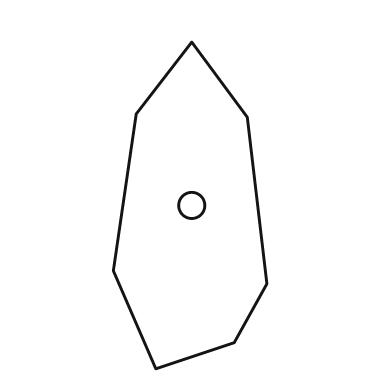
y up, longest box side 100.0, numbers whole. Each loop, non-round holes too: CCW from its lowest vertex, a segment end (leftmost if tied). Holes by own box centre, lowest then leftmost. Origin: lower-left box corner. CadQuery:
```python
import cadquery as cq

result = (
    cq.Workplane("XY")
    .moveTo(13.0, 0.0)
    .lineTo(37.0, 8.0)
    .lineTo(47.0, 26.0)
    .lineTo(41.0, 77.0)
    .lineTo(24.0, 100.0)
    .lineTo(7.0, 78.0)
    .lineTo(0.0, 30.0)
    .close()
    .moveTo(24.0, 50.0)
    .circle(4.0)
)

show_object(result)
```